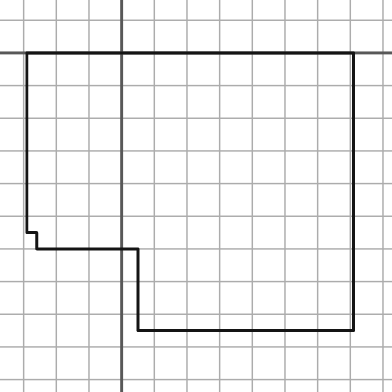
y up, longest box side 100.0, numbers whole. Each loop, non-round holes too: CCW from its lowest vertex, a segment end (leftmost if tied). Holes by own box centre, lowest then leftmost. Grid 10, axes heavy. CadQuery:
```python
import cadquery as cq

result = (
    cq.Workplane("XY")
    .moveTo(5.0, -85.0)
    .lineTo(71.0, -85.0)
    .lineTo(71.0, 0.0)
    .lineTo(-29.0, 0.0)
    .lineTo(-29.0, -55.0)
    .lineTo(-26.0, -55.0)
    .lineTo(-26.0, -60.0)
    .lineTo(5.0, -60.0)
    .close()
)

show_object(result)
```